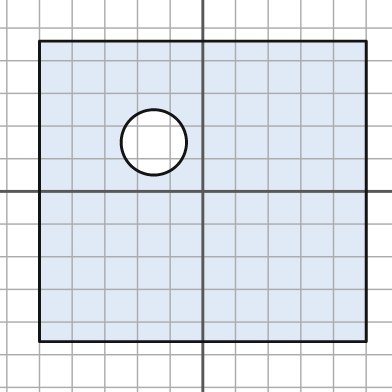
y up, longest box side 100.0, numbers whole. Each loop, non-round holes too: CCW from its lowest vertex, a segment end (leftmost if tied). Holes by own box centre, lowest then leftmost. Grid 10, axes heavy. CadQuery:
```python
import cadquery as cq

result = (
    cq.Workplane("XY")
    .moveTo(-50.0, -46.0)
    .lineTo(50.0, -46.0)
    .lineTo(50.0, 46.0)
    .lineTo(-50.0, 46.0)
    .close()
    .moveTo(-15.0, 15.0)
    .circle(10.0)
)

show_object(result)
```